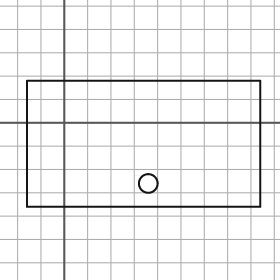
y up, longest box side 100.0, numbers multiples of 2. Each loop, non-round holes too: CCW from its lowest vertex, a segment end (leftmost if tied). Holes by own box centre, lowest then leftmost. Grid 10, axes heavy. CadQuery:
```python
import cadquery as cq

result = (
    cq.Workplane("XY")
    .moveTo(-16.0, -36.0)
    .lineTo(84.0, -36.0)
    .lineTo(84.0, 18.0)
    .lineTo(-16.0, 18.0)
    .close()
    .moveTo(36.0, -26.0)
    .circle(4.0)
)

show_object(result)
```